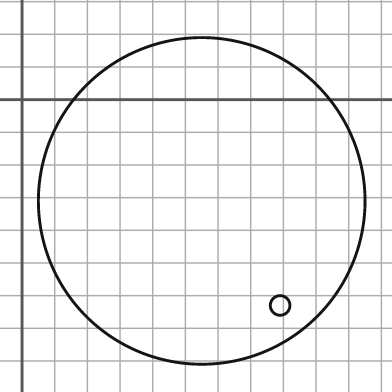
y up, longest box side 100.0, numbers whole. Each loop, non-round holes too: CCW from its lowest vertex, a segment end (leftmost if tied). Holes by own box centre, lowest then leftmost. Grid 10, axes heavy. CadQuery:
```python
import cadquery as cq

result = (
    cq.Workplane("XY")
    .moveTo(55.0, -31.0)
    .circle(50.0)
    .moveTo(79.0, -63.0)
    .circle(3.0)
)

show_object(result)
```